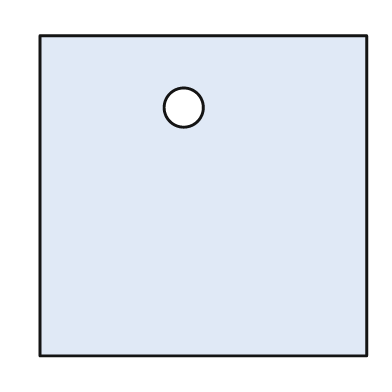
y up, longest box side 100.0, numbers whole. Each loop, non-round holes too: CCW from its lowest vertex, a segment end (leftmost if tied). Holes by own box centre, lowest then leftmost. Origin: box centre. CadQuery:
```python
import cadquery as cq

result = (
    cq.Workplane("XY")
    .moveTo(-50.0, -49.0)
    .lineTo(50.0, -49.0)
    .lineTo(50.0, 49.0)
    .lineTo(-50.0, 49.0)
    .close()
    .moveTo(-6.0, 27.0)
    .circle(6.0)
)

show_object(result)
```